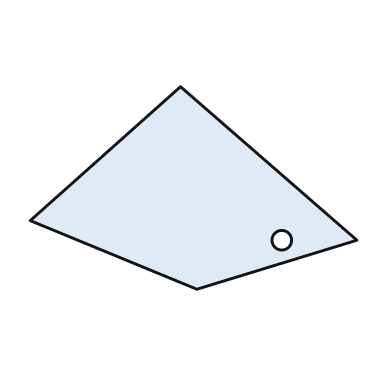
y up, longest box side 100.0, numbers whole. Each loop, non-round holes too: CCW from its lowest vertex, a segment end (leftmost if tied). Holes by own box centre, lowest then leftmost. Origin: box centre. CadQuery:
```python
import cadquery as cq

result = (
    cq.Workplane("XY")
    .moveTo(1.0, -31.0)
    .lineTo(50.0, -16.0)
    .lineTo(-4.0, 31.0)
    .lineTo(-50.0, -10.0)
    .close()
    .moveTo(27.0, -16.0)
    .circle(3.0)
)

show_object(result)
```